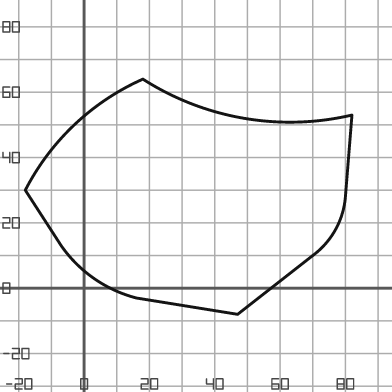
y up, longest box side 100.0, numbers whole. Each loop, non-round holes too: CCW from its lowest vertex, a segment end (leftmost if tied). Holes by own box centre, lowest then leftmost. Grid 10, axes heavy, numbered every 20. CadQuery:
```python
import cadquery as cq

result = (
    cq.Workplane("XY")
    .moveTo(47.0, -8.0)
    .lineTo(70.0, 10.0)
    .threePointArc((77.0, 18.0), (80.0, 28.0))
    .lineTo(82.0, 53.0)
    .threePointArc((49.0, 52.0), (18.0, 64.0))
    .threePointArc((-3.0, 50.0), (-18.0, 30.0))
    .lineTo(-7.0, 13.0)
    .threePointArc((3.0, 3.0), (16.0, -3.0))
    .close()
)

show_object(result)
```